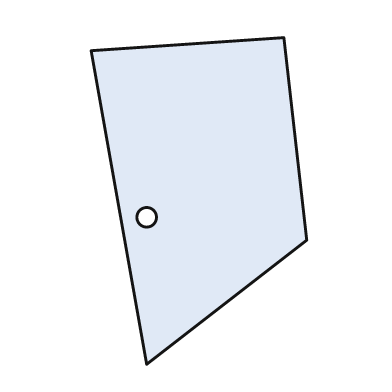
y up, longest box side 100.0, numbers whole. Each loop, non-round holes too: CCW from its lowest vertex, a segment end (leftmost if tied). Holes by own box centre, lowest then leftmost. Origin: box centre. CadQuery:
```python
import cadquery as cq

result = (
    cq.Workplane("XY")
    .moveTo(-16.0, -50.0)
    .lineTo(33.0, -12.0)
    .lineTo(26.0, 50.0)
    .lineTo(-33.0, 46.0)
    .close()
    .moveTo(-16.0, -5.0)
    .circle(3.0)
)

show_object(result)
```